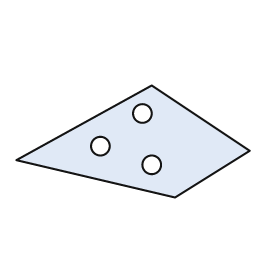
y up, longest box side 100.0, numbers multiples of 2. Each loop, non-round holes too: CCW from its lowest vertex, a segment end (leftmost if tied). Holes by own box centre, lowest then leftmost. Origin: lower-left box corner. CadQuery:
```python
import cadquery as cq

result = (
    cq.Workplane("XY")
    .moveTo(68.0, 0.0)
    .lineTo(100.0, 20.0)
    .lineTo(58.0, 48.0)
    .lineTo(0.0, 16.0)
    .close()
    .moveTo(58.0, 14.0)
    .circle(4.0)
    .moveTo(36.0, 22.0)
    .circle(4.0)
    .moveTo(54.0, 36.0)
    .circle(4.0)
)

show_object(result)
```